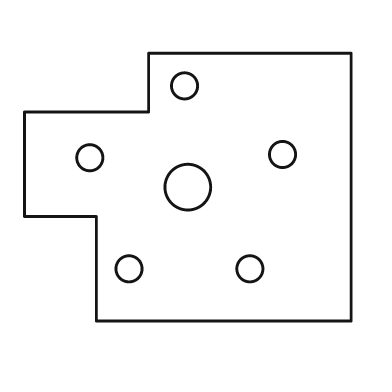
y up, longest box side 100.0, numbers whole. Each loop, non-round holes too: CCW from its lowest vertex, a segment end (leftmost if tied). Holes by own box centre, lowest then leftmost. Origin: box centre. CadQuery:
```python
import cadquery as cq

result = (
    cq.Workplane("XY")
    .moveTo(-28.0, -41.0)
    .lineTo(50.0, -41.0)
    .lineTo(50.0, 41.0)
    .lineTo(-12.0, 41.0)
    .lineTo(-12.0, 23.0)
    .lineTo(-50.0, 23.0)
    .lineTo(-50.0, -9.0)
    .lineTo(-28.0, -9.0)
    .close()
    .moveTo(-18.0, -25.0)
    .circle(4.0)
    .moveTo(19.0, -25.0)
    .circle(4.0)
    .moveTo(0.0, 0.0)
    .circle(7.0)
    .moveTo(-30.0, 9.0)
    .circle(4.0)
    .moveTo(29.0, 10.0)
    .circle(4.0)
    .moveTo(-1.0, 31.0)
    .circle(4.0)
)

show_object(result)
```